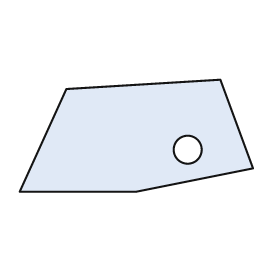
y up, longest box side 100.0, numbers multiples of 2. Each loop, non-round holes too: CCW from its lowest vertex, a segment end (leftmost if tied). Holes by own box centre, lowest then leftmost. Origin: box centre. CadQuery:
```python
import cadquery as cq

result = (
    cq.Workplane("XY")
    .moveTo(-50.0, -24.0)
    .lineTo(0.0, -24.0)
    .lineTo(50.0, -14.0)
    .lineTo(36.0, 24.0)
    .lineTo(-30.0, 20.0)
    .close()
    .moveTo(22.0, -6.0)
    .circle(6.0)
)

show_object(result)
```